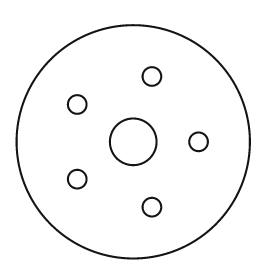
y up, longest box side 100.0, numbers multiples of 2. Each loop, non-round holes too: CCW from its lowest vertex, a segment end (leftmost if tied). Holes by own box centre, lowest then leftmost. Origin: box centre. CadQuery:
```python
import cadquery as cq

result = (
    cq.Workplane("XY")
    .moveTo(0.0, 0.0)
    .circle(50.0)
    .moveTo(8.0, -28.0)
    .circle(4.0)
    .moveTo(-24.0, -16.0)
    .circle(4.0)
    .moveTo(0.0, 0.0)
    .circle(10.0)
    .moveTo(28.0, 0.0)
    .circle(4.0)
    .moveTo(-24.0, 16.0)
    .circle(4.0)
    .moveTo(8.0, 28.0)
    .circle(4.0)
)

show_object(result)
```